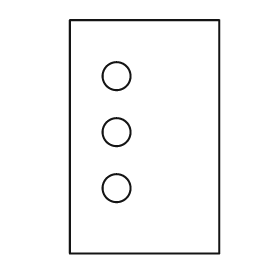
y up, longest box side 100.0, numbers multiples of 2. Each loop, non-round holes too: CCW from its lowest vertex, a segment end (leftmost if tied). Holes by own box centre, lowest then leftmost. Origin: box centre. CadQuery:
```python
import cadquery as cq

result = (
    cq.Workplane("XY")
    .moveTo(-32.0, -50.0)
    .lineTo(32.0, -50.0)
    .lineTo(32.0, 50.0)
    .lineTo(-32.0, 50.0)
    .close()
    .moveTo(-12.0, -22.0)
    .circle(6.0)
    .moveTo(-12.0, 2.0)
    .circle(6.0)
    .moveTo(-12.0, 26.0)
    .circle(6.0)
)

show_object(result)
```